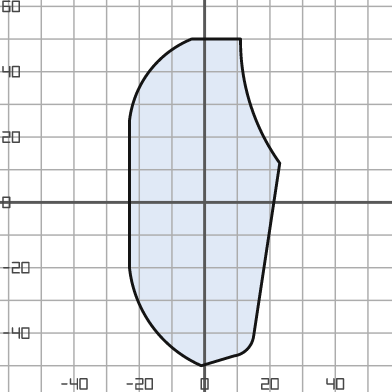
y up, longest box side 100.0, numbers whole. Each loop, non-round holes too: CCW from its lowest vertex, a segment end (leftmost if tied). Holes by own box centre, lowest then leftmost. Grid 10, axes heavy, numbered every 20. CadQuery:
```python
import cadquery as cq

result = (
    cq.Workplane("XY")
    .moveTo(-1.0, -50.0)
    .lineTo(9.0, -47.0)
    .threePointArc((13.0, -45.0), (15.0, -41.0))
    .lineTo(23.0, 12.0)
    .threePointArc((14.0, 30.0), (11.0, 50.0))
    .lineTo(-4.0, 50.0)
    .threePointArc((-17.0, 40.0), (-23.0, 25.0))
    .lineTo(-23.0, -20.0)
    .threePointArc((-16.0, -38.0), (-1.0, -50.0))
    .close()
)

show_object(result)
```